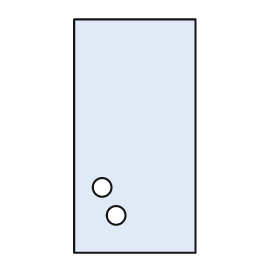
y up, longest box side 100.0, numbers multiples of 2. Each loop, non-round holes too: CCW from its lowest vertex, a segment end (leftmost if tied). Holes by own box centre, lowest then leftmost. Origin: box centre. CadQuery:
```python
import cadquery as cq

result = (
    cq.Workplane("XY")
    .moveTo(-26.0, -50.0)
    .lineTo(26.0, -50.0)
    .lineTo(26.0, 50.0)
    .lineTo(-26.0, 50.0)
    .close()
    .moveTo(-8.0, -34.0)
    .circle(4.0)
    .moveTo(-14.0, -22.0)
    .circle(4.0)
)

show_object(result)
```